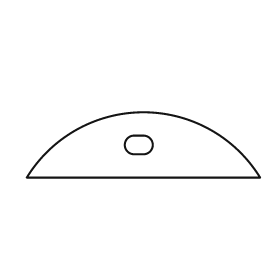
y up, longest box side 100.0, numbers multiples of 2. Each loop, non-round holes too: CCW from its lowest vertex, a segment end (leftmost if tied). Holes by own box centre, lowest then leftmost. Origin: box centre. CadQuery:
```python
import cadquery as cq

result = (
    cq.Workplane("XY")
    .moveTo(-50.0, -14.0)
    .lineTo(50.0, -14.0)
    .threePointArc((0.0, 14.0), (-50.0, -14.0))
    .close()
    .moveTo(-4.0, -4.0)
    .lineTo(0.0, -4.0)
    .threePointArc((4.0, 0.0), (0.0, 4.0))
    .lineTo(-4.0, 4.0)
    .threePointArc((-8.0, 0.0), (-4.0, -4.0))
    .close()
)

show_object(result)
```